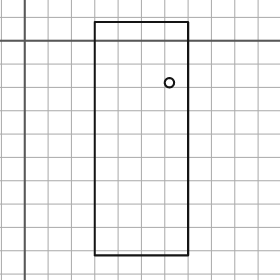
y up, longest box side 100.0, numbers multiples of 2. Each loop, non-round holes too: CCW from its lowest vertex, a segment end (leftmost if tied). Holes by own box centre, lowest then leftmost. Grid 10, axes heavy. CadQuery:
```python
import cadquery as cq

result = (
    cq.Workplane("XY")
    .moveTo(30.0, -92.0)
    .lineTo(70.0, -92.0)
    .lineTo(70.0, 8.0)
    .lineTo(30.0, 8.0)
    .close()
    .moveTo(62.0, -18.0)
    .circle(2.0)
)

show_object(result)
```